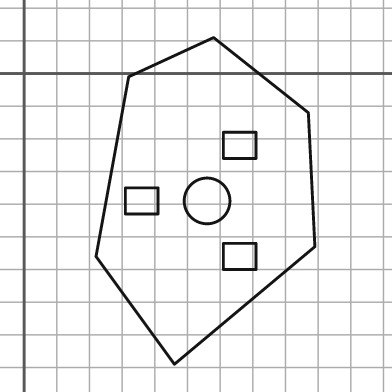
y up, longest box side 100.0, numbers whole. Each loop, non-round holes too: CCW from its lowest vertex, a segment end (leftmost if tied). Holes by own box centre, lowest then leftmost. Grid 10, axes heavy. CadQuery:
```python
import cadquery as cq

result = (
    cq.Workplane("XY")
    .moveTo(46.0, -89.0)
    .lineTo(89.0, -53.0)
    .lineTo(87.0, -12.0)
    .lineTo(58.0, 11.0)
    .lineTo(32.0, -1.0)
    .lineTo(22.0, -56.0)
    .close()
    .moveTo(61.0, -60.0)
    .lineTo(71.0, -60.0)
    .lineTo(71.0, -52.0)
    .lineTo(61.0, -52.0)
    .close()
    .moveTo(31.0, -43.0)
    .lineTo(41.0, -43.0)
    .lineTo(41.0, -35.0)
    .lineTo(31.0, -35.0)
    .close()
    .moveTo(56.0, -39.0)
    .circle(7.0)
    .moveTo(61.0, -26.0)
    .lineTo(71.0, -26.0)
    .lineTo(71.0, -18.0)
    .lineTo(61.0, -18.0)
    .close()
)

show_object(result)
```